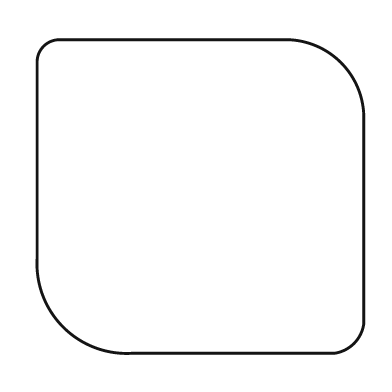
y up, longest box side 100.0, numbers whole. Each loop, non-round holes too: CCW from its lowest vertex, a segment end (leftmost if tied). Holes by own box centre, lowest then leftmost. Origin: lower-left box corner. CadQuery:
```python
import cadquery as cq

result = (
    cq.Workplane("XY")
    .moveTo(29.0, 0.0)
    .lineTo(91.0, 0.0)
    .threePointArc((97.0, 3.0), (100.0, 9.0))
    .lineTo(100.0, 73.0)
    .threePointArc((93.0, 89.0), (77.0, 96.0))
    .lineTo(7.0, 96.0)
    .threePointArc((2.0, 94.0), (0.0, 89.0))
    .lineTo(0.0, 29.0)
    .threePointArc((8.0, 8.0), (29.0, 0.0))
    .close()
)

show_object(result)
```